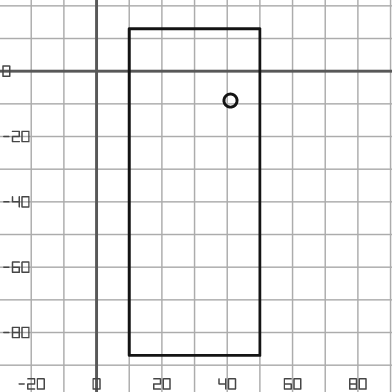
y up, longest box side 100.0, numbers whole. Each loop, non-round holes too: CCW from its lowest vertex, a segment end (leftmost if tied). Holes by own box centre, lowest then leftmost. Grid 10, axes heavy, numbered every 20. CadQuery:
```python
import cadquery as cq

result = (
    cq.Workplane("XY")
    .moveTo(10.0, -87.0)
    .lineTo(50.0, -87.0)
    .lineTo(50.0, 13.0)
    .lineTo(10.0, 13.0)
    .close()
    .moveTo(41.0, -9.0)
    .circle(2.0)
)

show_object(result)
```